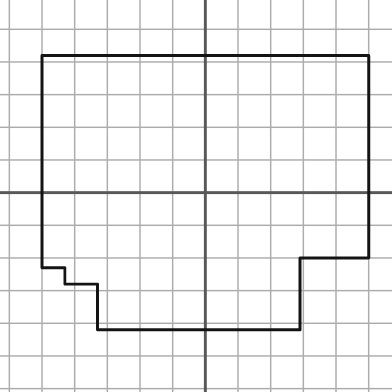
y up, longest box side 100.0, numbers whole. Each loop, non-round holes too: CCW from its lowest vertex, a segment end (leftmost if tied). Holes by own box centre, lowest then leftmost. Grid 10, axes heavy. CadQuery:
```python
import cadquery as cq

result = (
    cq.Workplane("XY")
    .moveTo(-33.0, -42.0)
    .lineTo(29.0, -42.0)
    .lineTo(29.0, -20.0)
    .lineTo(50.0, -20.0)
    .lineTo(50.0, 42.0)
    .lineTo(-50.0, 42.0)
    .lineTo(-50.0, -23.0)
    .lineTo(-43.0, -23.0)
    .lineTo(-43.0, -28.0)
    .lineTo(-33.0, -28.0)
    .close()
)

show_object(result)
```